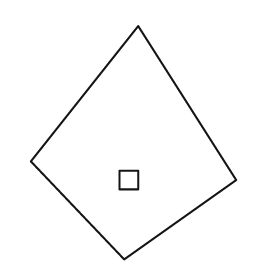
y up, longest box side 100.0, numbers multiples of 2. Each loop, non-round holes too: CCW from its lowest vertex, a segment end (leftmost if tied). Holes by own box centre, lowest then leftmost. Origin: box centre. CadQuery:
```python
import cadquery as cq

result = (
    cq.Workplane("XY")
    .moveTo(-4.0, -50.0)
    .lineTo(44.0, -16.0)
    .lineTo(2.0, 50.0)
    .lineTo(-44.0, -8.0)
    .close()
    .moveTo(-6.0, -20.0)
    .lineTo(2.0, -20.0)
    .lineTo(2.0, -12.0)
    .lineTo(-6.0, -12.0)
    .close()
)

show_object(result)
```